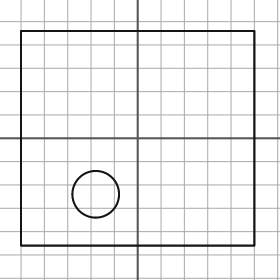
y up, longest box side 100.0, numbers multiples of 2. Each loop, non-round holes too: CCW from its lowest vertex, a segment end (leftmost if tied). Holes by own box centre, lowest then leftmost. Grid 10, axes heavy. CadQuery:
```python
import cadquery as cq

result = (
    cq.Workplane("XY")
    .moveTo(-50.0, -46.0)
    .lineTo(50.0, -46.0)
    .lineTo(50.0, 46.0)
    .lineTo(-50.0, 46.0)
    .close()
    .moveTo(-18.0, -24.0)
    .circle(10.0)
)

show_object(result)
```